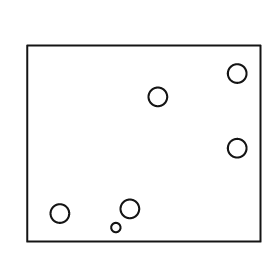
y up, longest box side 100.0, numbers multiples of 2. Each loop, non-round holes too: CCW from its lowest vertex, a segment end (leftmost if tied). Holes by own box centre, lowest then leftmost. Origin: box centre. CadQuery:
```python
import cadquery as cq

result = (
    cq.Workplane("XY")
    .moveTo(-50.0, -42.0)
    .lineTo(50.0, -42.0)
    .lineTo(50.0, 42.0)
    .lineTo(-50.0, 42.0)
    .close()
    .moveTo(-12.0, -36.0)
    .circle(2.0)
    .moveTo(-36.0, -30.0)
    .circle(4.0)
    .moveTo(-6.0, -28.0)
    .circle(4.0)
    .moveTo(40.0, -2.0)
    .circle(4.0)
    .moveTo(6.0, 20.0)
    .circle(4.0)
    .moveTo(40.0, 30.0)
    .circle(4.0)
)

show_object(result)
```